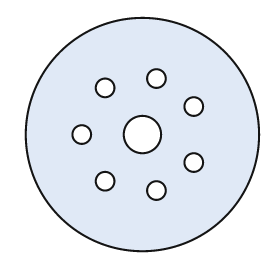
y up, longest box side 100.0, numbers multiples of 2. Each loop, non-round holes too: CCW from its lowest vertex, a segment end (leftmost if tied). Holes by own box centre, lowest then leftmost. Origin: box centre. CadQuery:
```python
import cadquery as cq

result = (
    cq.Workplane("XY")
    .moveTo(0.0, 0.0)
    .circle(50.0)
    .moveTo(6.0, -24.0)
    .circle(4.0)
    .moveTo(-16.0, -20.0)
    .circle(4.0)
    .moveTo(22.0, -12.0)
    .circle(4.0)
    .moveTo(-26.0, 0.0)
    .circle(4.0)
    .moveTo(0.0, 0.0)
    .circle(8.0)
    .moveTo(22.0, 12.0)
    .circle(4.0)
    .moveTo(-16.0, 20.0)
    .circle(4.0)
    .moveTo(6.0, 24.0)
    .circle(4.0)
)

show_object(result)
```